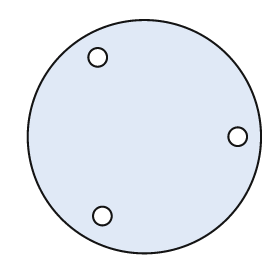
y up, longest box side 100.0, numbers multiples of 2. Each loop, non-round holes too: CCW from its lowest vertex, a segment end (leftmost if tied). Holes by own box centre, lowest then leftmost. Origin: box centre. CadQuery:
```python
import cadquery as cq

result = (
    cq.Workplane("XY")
    .moveTo(0.0, 0.0)
    .circle(50.0)
    .moveTo(-18.0, -34.0)
    .circle(4.0)
    .moveTo(40.0, 0.0)
    .circle(4.0)
    .moveTo(-20.0, 34.0)
    .circle(4.0)
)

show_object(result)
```